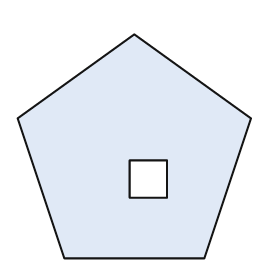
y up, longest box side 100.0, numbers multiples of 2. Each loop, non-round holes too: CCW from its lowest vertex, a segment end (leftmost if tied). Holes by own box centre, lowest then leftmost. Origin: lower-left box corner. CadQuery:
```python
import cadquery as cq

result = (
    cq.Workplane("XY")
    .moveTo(20.0, 0.0)
    .lineTo(80.0, 0.0)
    .lineTo(100.0, 60.0)
    .lineTo(50.0, 96.0)
    .lineTo(0.0, 60.0)
    .close()
    .moveTo(48.0, 26.0)
    .lineTo(64.0, 26.0)
    .lineTo(64.0, 42.0)
    .lineTo(48.0, 42.0)
    .close()
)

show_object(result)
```